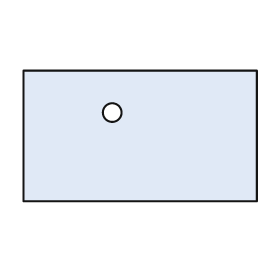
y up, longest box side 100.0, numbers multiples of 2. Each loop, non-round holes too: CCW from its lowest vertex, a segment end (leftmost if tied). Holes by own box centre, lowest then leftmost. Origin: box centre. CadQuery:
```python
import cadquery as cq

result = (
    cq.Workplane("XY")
    .moveTo(-50.0, -28.0)
    .lineTo(50.0, -28.0)
    .lineTo(50.0, 28.0)
    .lineTo(-50.0, 28.0)
    .close()
    .moveTo(-12.0, 10.0)
    .circle(4.0)
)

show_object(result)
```